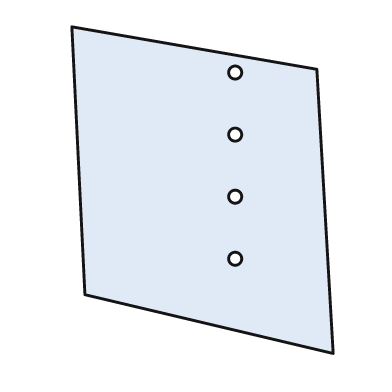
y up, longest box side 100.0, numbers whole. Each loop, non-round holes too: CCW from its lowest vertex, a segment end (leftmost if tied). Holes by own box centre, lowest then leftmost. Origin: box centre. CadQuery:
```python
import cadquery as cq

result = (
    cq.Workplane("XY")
    .moveTo(40.0, -50.0)
    .lineTo(35.0, 37.0)
    .lineTo(-40.0, 50.0)
    .lineTo(-36.0, -32.0)
    .close()
    .moveTo(10.0, -21.0)
    .circle(2.0)
    .moveTo(10.0, -2.0)
    .circle(2.0)
    .moveTo(10.0, 17.0)
    .circle(2.0)
    .moveTo(10.0, 36.0)
    .circle(2.0)
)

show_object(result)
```